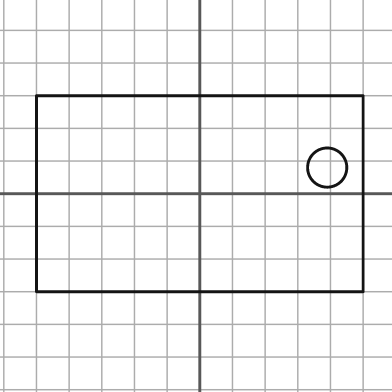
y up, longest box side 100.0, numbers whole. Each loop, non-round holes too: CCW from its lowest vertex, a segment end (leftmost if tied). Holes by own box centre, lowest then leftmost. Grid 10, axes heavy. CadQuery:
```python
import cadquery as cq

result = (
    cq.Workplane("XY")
    .moveTo(-50.0, -30.0)
    .lineTo(50.0, -30.0)
    .lineTo(50.0, 30.0)
    .lineTo(-50.0, 30.0)
    .close()
    .moveTo(39.0, 8.0)
    .circle(6.0)
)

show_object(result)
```